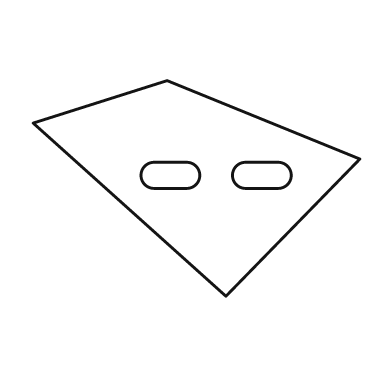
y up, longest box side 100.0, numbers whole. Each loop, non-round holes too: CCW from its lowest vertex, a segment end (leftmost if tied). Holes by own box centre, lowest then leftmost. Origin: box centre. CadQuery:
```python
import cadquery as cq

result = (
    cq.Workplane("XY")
    .moveTo(9.0, -33.0)
    .lineTo(50.0, 9.0)
    .lineTo(-9.0, 33.0)
    .lineTo(-50.0, 20.0)
    .close()
    .moveTo(-13.0, 0.0)
    .lineTo(-3.0, 0.0)
    .threePointArc((1.0, 4.0), (-3.0, 8.0))
    .lineTo(-13.0, 8.0)
    .threePointArc((-17.0, 4.0), (-13.0, 0.0))
    .close()
    .moveTo(15.0, 0.0)
    .lineTo(25.0, 0.0)
    .threePointArc((29.0, 4.0), (25.0, 8.0))
    .lineTo(15.0, 8.0)
    .threePointArc((11.0, 4.0), (15.0, 0.0))
    .close()
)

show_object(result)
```